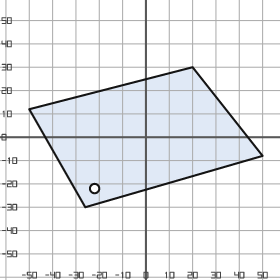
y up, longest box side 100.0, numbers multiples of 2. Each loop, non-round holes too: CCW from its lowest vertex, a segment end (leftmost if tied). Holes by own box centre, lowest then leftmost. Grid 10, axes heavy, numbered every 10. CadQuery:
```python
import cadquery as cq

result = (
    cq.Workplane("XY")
    .moveTo(-26.0, -30.0)
    .lineTo(50.0, -8.0)
    .lineTo(20.0, 30.0)
    .lineTo(-50.0, 12.0)
    .close()
    .moveTo(-22.0, -22.0)
    .circle(2.0)
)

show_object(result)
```